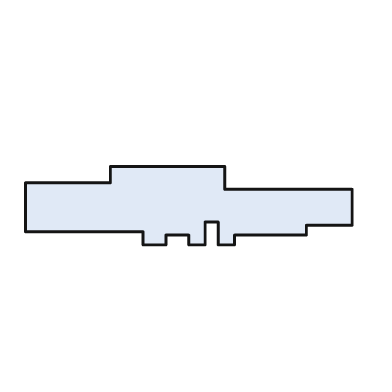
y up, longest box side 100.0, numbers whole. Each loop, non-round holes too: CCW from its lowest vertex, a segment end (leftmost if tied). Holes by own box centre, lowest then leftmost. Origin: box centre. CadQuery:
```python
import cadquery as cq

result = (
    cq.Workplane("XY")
    .moveTo(-14.0, -12.0)
    .lineTo(-7.0, -12.0)
    .lineTo(-7.0, -9.0)
    .lineTo(0.0, -9.0)
    .lineTo(0.0, -12.0)
    .lineTo(5.0, -12.0)
    .lineTo(5.0, -5.0)
    .lineTo(9.0, -5.0)
    .lineTo(9.0, -12.0)
    .lineTo(14.0, -12.0)
    .lineTo(14.0, -9.0)
    .lineTo(36.0, -9.0)
    .lineTo(36.0, -6.0)
    .lineTo(50.0, -6.0)
    .lineTo(50.0, 5.0)
    .lineTo(11.0, 5.0)
    .lineTo(11.0, 12.0)
    .lineTo(-24.0, 12.0)
    .lineTo(-24.0, 7.0)
    .lineTo(-50.0, 7.0)
    .lineTo(-50.0, -8.0)
    .lineTo(-14.0, -8.0)
    .close()
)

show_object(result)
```